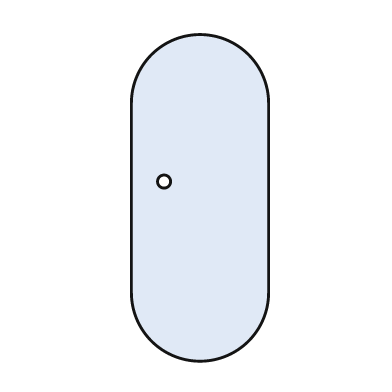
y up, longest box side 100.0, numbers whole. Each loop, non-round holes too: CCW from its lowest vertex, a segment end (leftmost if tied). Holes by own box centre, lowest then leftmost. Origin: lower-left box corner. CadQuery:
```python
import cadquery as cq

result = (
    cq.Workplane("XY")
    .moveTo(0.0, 21.0)
    .threePointArc((21.0, 0.0), (42.0, 21.0))
    .lineTo(42.0, 79.0)
    .threePointArc((21.0, 100.0), (0.0, 79.0))
    .close()
    .moveTo(10.0, 55.0)
    .circle(2.0)
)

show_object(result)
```